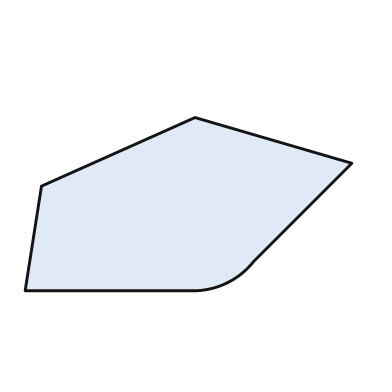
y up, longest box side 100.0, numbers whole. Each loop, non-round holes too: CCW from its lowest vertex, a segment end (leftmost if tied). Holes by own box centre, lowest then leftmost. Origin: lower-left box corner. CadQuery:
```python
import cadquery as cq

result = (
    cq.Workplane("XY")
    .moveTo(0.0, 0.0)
    .lineTo(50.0, 0.0)
    .threePointArc((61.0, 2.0), (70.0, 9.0))
    .lineTo(100.0, 39.0)
    .lineTo(52.0, 53.0)
    .lineTo(5.0, 32.0)
    .close()
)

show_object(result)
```